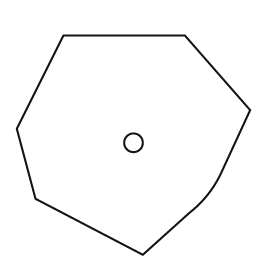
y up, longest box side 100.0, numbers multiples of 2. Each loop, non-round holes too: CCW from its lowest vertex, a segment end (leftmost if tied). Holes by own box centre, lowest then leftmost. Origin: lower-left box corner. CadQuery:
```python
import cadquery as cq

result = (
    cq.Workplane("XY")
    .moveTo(54.0, 0.0)
    .lineTo(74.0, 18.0)
    .threePointArc((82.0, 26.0), (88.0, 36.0))
    .lineTo(100.0, 62.0)
    .lineTo(72.0, 94.0)
    .lineTo(20.0, 94.0)
    .lineTo(0.0, 54.0)
    .lineTo(8.0, 24.0)
    .close()
    .moveTo(50.0, 48.0)
    .circle(4.0)
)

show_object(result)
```